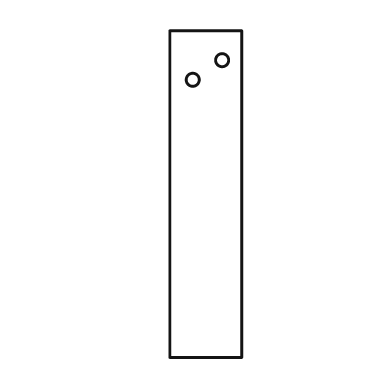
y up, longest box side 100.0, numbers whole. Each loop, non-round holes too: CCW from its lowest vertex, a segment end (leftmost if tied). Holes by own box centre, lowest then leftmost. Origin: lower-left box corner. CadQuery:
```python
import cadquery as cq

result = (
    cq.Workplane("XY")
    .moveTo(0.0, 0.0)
    .lineTo(22.0, 0.0)
    .lineTo(22.0, 100.0)
    .lineTo(0.0, 100.0)
    .close()
    .moveTo(7.0, 85.0)
    .circle(2.0)
    .moveTo(16.0, 91.0)
    .circle(2.0)
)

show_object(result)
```